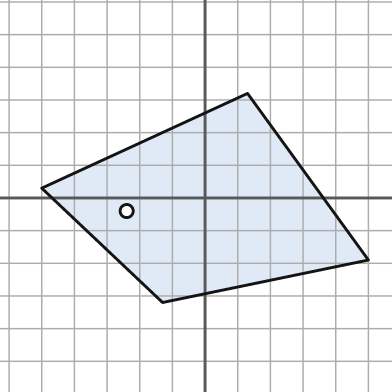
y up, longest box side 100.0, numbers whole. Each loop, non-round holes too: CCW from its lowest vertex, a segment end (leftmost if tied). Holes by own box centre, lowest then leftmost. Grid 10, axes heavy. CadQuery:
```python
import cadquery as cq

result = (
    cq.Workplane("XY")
    .moveTo(-13.0, -32.0)
    .lineTo(50.0, -19.0)
    .lineTo(13.0, 32.0)
    .lineTo(-50.0, 3.0)
    .close()
    .moveTo(-24.0, -4.0)
    .circle(2.0)
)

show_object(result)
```